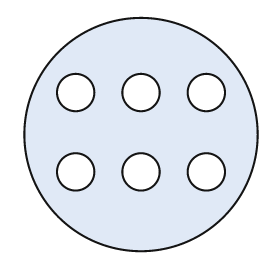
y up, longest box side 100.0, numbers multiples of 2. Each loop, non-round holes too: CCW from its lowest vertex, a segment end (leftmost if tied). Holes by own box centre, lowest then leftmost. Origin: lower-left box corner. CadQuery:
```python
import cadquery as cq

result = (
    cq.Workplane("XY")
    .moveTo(50.0, 50.0)
    .circle(50.0)
    .moveTo(22.0, 34.0)
    .circle(8.0)
    .moveTo(50.0, 34.0)
    .circle(8.0)
    .moveTo(78.0, 34.0)
    .circle(8.0)
    .moveTo(22.0, 68.0)
    .circle(8.0)
    .moveTo(50.0, 68.0)
    .circle(8.0)
    .moveTo(78.0, 68.0)
    .circle(8.0)
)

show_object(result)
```